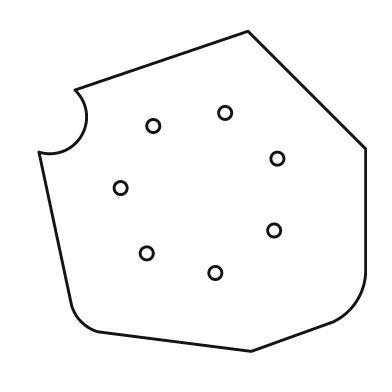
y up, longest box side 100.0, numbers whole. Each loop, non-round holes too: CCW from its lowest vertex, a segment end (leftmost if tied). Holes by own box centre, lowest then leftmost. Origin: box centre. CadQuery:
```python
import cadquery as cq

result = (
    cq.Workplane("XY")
    .moveTo(15.0, -49.0)
    .lineTo(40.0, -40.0)
    .threePointArc((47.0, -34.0), (50.0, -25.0))
    .lineTo(50.0, 13.0)
    .lineTo(14.0, 49.0)
    .lineTo(-39.0, 31.0)
    .threePointArc((-37.0, 17.0), (-50.0, 12.0))
    .lineTo(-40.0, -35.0)
    .threePointArc((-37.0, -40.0), (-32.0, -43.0))
    .close()
    .moveTo(4.0, -25.0)
    .circle(2.0)
    .moveTo(-17.0, -19.0)
    .circle(2.0)
    .moveTo(22.0, -12.0)
    .circle(2.0)
    .moveTo(-25.0, 1.0)
    .circle(2.0)
    .moveTo(23.0, 10.0)
    .circle(2.0)
    .moveTo(-15.0, 20.0)
    .circle(2.0)
    .moveTo(7.0, 24.0)
    .circle(2.0)
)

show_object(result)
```